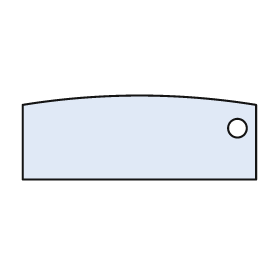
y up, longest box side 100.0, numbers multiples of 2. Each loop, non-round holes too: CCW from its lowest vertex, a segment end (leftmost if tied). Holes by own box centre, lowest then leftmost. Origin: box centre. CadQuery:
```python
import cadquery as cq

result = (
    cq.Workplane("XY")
    .moveTo(-50.0, -18.0)
    .lineTo(50.0, -18.0)
    .lineTo(50.0, 14.0)
    .threePointArc((0.0, 18.0), (-50.0, 14.0))
    .close()
    .moveTo(42.0, 4.0)
    .circle(4.0)
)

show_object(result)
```